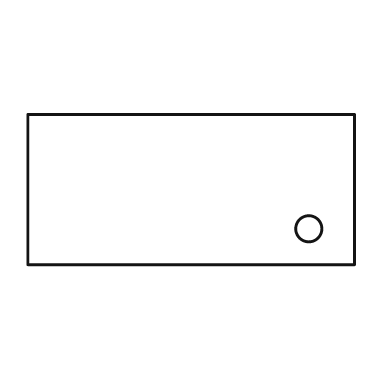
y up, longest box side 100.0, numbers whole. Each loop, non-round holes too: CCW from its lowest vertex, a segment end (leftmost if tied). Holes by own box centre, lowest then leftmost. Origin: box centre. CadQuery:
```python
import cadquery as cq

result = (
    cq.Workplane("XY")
    .moveTo(-50.0, -23.0)
    .lineTo(50.0, -23.0)
    .lineTo(50.0, 23.0)
    .lineTo(-50.0, 23.0)
    .close()
    .moveTo(36.0, -12.0)
    .circle(4.0)
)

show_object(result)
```